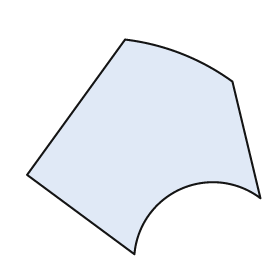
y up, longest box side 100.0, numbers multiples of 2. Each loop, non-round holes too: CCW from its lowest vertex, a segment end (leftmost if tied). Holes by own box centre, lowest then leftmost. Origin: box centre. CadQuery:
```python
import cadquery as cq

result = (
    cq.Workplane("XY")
    .moveTo(-4.0, -46.0)
    .threePointArc((16.0, -18.0), (50.0, -22.0))
    .lineTo(38.0, 28.0)
    .threePointArc((16.0, 40.0), (-8.0, 46.0))
    .lineTo(-50.0, -12.0)
    .close()
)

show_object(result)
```